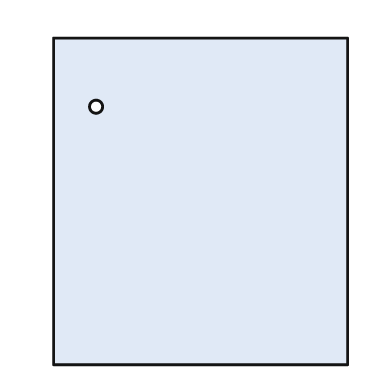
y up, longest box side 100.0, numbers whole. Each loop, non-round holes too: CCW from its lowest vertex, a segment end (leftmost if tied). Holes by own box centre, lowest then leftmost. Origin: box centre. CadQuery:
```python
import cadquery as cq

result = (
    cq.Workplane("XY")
    .moveTo(-45.0, -50.0)
    .lineTo(45.0, -50.0)
    .lineTo(45.0, 50.0)
    .lineTo(-45.0, 50.0)
    .close()
    .moveTo(-32.0, 29.0)
    .circle(2.0)
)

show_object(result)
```